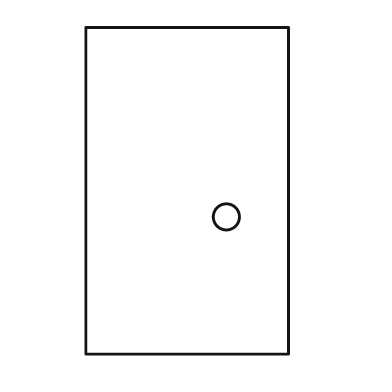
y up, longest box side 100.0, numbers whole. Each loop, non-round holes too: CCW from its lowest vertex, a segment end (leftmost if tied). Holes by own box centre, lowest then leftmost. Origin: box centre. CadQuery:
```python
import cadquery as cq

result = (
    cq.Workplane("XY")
    .moveTo(-31.0, -50.0)
    .lineTo(31.0, -50.0)
    .lineTo(31.0, 50.0)
    .lineTo(-31.0, 50.0)
    .close()
    .moveTo(12.0, -8.0)
    .circle(4.0)
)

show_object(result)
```